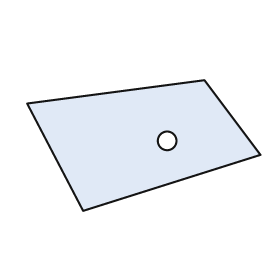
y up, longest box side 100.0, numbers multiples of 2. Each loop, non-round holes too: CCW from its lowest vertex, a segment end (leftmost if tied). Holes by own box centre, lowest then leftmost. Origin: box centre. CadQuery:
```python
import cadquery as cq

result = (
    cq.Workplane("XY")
    .moveTo(-26.0, -28.0)
    .lineTo(50.0, -4.0)
    .lineTo(26.0, 28.0)
    .lineTo(-50.0, 18.0)
    .close()
    .moveTo(10.0, 2.0)
    .circle(4.0)
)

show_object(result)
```